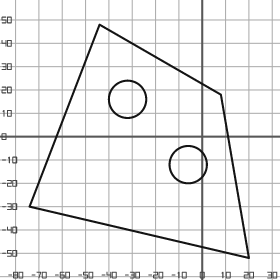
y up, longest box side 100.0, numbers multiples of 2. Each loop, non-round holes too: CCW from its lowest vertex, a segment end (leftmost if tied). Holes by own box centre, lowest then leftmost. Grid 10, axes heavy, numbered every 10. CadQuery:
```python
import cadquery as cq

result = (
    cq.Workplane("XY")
    .moveTo(20.0, -52.0)
    .lineTo(8.0, 18.0)
    .lineTo(-44.0, 48.0)
    .lineTo(-74.0, -30.0)
    .close()
    .moveTo(-6.0, -12.0)
    .circle(8.0)
    .moveTo(-32.0, 16.0)
    .circle(8.0)
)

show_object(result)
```